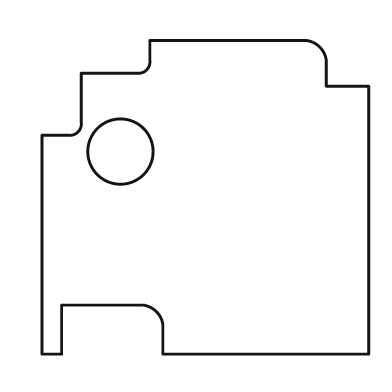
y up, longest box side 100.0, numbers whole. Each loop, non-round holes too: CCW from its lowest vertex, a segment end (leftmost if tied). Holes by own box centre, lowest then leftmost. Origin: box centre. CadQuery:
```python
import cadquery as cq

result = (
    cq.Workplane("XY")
    .moveTo(-50.0, -48.0)
    .lineTo(-44.0, -48.0)
    .lineTo(-44.0, -33.0)
    .lineTo(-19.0, -33.0)
    .threePointArc((-15.0, -35.0), (-13.0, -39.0))
    .lineTo(-13.0, -48.0)
    .lineTo(50.0, -48.0)
    .lineTo(50.0, 34.0)
    .lineTo(37.0, 34.0)
    .lineTo(37.0, 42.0)
    .threePointArc((35.0, 46.0), (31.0, 48.0))
    .lineTo(-17.0, 48.0)
    .lineTo(-17.0, 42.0)
    .threePointArc((-18.0, 39.0), (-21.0, 38.0))
    .lineTo(-38.0, 38.0)
    .lineTo(-38.0, 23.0)
    .threePointArc((-39.0, 20.0), (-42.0, 19.0))
    .lineTo(-50.0, 19.0)
    .close()
    .moveTo(-26.0, 14.0)
    .circle(10.0)
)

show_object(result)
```